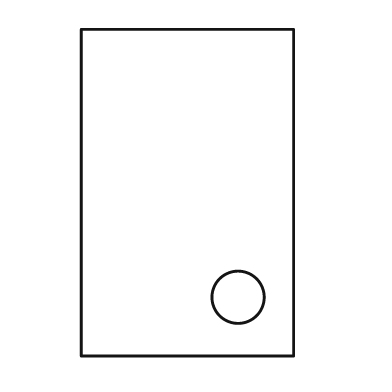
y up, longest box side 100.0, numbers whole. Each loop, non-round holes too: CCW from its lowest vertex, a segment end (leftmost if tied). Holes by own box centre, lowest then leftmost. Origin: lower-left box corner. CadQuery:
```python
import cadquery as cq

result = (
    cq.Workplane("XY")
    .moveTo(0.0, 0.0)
    .lineTo(65.0, 0.0)
    .lineTo(65.0, 100.0)
    .lineTo(0.0, 100.0)
    .close()
    .moveTo(48.0, 18.0)
    .circle(8.0)
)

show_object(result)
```